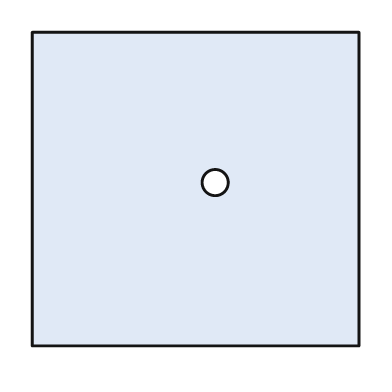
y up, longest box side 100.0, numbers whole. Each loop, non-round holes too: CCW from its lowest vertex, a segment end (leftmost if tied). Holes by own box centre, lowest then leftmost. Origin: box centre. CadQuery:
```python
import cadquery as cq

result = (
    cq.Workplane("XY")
    .moveTo(-50.0, -48.0)
    .lineTo(50.0, -48.0)
    .lineTo(50.0, 48.0)
    .lineTo(-50.0, 48.0)
    .close()
    .moveTo(6.0, 2.0)
    .circle(4.0)
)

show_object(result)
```